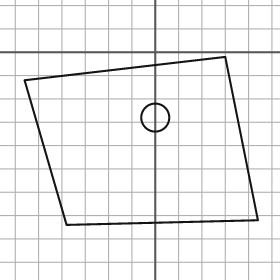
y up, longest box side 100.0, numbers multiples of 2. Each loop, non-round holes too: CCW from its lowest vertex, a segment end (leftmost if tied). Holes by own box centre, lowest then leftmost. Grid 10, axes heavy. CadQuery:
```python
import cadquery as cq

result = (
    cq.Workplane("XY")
    .moveTo(-38.0, -74.0)
    .lineTo(44.0, -72.0)
    .lineTo(30.0, -2.0)
    .lineTo(-56.0, -12.0)
    .close()
    .moveTo(0.0, -28.0)
    .circle(6.0)
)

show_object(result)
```